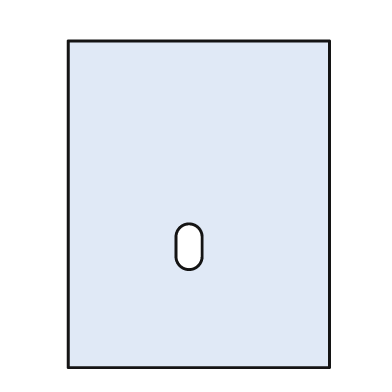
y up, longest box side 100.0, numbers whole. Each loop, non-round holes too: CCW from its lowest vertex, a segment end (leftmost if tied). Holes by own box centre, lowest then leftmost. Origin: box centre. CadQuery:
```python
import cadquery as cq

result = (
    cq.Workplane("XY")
    .moveTo(-40.0, -50.0)
    .lineTo(40.0, -50.0)
    .lineTo(40.0, 50.0)
    .lineTo(-40.0, 50.0)
    .close()
    .moveTo(-7.0, -16.0)
    .threePointArc((-3.0, -20.0), (1.0, -16.0))
    .lineTo(1.0, -10.0)
    .threePointArc((-3.0, -6.0), (-7.0, -10.0))
    .close()
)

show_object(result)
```